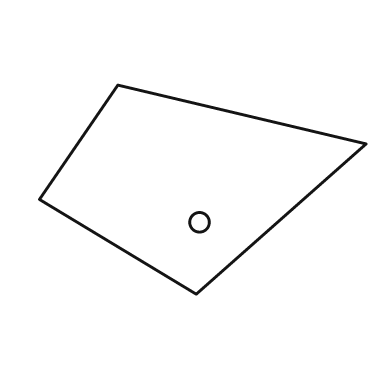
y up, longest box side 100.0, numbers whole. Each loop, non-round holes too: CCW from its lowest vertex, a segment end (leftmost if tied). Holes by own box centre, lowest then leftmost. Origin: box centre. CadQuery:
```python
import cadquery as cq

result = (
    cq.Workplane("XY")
    .moveTo(-2.0, -32.0)
    .lineTo(50.0, 14.0)
    .lineTo(-26.0, 32.0)
    .lineTo(-50.0, -3.0)
    .close()
    .moveTo(-1.0, -10.0)
    .circle(3.0)
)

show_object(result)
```